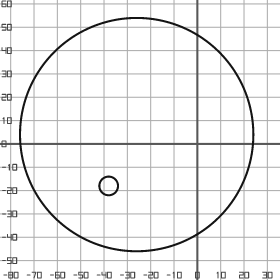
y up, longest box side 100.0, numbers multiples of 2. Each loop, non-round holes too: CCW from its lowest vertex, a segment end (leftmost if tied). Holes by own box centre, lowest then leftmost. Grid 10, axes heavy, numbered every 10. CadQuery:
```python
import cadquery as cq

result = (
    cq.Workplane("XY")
    .moveTo(-26.0, 4.0)
    .circle(50.0)
    .moveTo(-38.0, -18.0)
    .circle(4.0)
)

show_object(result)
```